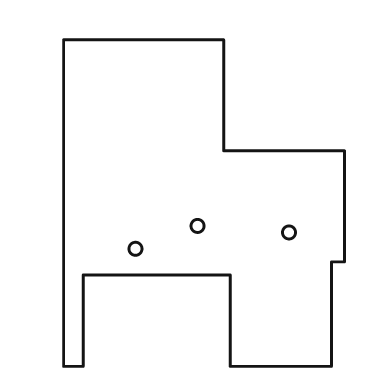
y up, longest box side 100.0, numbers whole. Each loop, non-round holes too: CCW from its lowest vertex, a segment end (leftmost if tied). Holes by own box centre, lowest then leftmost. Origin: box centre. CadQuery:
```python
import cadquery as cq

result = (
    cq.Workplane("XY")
    .moveTo(-43.0, -50.0)
    .lineTo(-37.0, -50.0)
    .lineTo(-37.0, -22.0)
    .lineTo(8.0, -22.0)
    .lineTo(8.0, -50.0)
    .lineTo(39.0, -50.0)
    .lineTo(39.0, -18.0)
    .lineTo(43.0, -18.0)
    .lineTo(43.0, 16.0)
    .lineTo(6.0, 16.0)
    .lineTo(6.0, 50.0)
    .lineTo(-43.0, 50.0)
    .close()
    .moveTo(-21.0, -14.0)
    .circle(2.0)
    .moveTo(26.0, -9.0)
    .circle(2.0)
    .moveTo(-2.0, -7.0)
    .circle(2.0)
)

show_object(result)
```